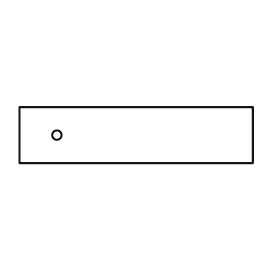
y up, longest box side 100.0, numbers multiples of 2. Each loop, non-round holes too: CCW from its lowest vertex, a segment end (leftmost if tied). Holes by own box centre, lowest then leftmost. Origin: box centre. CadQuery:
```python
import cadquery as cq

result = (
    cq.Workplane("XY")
    .moveTo(-50.0, -12.0)
    .lineTo(50.0, -12.0)
    .lineTo(50.0, 12.0)
    .lineTo(-50.0, 12.0)
    .close()
    .moveTo(-34.0, 0.0)
    .circle(2.0)
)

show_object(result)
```